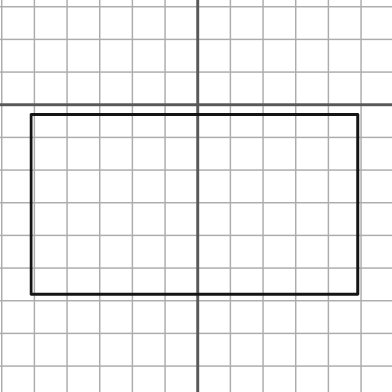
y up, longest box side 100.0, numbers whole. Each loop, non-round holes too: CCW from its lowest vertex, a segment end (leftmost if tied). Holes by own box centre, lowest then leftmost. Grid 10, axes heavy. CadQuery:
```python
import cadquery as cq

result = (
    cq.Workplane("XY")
    .moveTo(-51.0, -58.0)
    .lineTo(49.0, -58.0)
    .lineTo(49.0, -3.0)
    .lineTo(-51.0, -3.0)
    .close()
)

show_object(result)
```